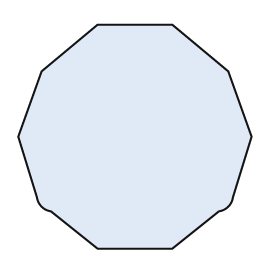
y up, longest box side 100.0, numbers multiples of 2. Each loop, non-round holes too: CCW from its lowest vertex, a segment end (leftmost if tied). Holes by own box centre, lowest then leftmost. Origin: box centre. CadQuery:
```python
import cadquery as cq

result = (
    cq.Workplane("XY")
    .moveTo(-16.0, -48.0)
    .lineTo(16.0, -48.0)
    .lineTo(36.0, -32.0)
    .threePointArc((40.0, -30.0), (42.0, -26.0))
    .lineTo(50.0, 0.0)
    .lineTo(40.0, 28.0)
    .lineTo(16.0, 48.0)
    .lineTo(-16.0, 48.0)
    .lineTo(-40.0, 28.0)
    .lineTo(-50.0, 0.0)
    .lineTo(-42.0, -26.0)
    .threePointArc((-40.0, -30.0), (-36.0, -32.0))
    .close()
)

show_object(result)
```